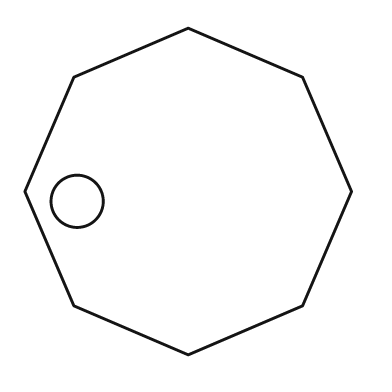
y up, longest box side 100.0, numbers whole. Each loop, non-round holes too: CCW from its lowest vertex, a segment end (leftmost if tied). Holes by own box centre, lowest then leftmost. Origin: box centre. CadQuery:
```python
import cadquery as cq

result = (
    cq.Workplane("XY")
    .moveTo(0.0, -50.0)
    .lineTo(35.0, -35.0)
    .lineTo(50.0, 0.0)
    .lineTo(35.0, 35.0)
    .lineTo(0.0, 50.0)
    .lineTo(-35.0, 35.0)
    .lineTo(-50.0, 0.0)
    .lineTo(-35.0, -35.0)
    .close()
    .moveTo(-34.0, -3.0)
    .circle(8.0)
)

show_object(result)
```